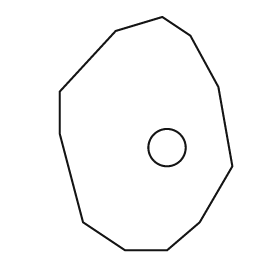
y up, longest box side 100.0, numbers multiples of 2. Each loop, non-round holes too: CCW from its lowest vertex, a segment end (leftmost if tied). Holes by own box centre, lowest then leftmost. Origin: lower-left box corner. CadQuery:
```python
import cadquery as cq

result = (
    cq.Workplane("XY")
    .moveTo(28.0, 0.0)
    .lineTo(46.0, 0.0)
    .lineTo(60.0, 12.0)
    .lineTo(74.0, 36.0)
    .lineTo(68.0, 70.0)
    .lineTo(56.0, 92.0)
    .lineTo(44.0, 100.0)
    .lineTo(24.0, 94.0)
    .lineTo(0.0, 68.0)
    .lineTo(0.0, 50.0)
    .lineTo(10.0, 12.0)
    .close()
    .moveTo(46.0, 44.0)
    .circle(8.0)
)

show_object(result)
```